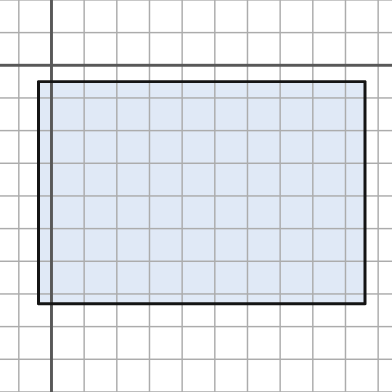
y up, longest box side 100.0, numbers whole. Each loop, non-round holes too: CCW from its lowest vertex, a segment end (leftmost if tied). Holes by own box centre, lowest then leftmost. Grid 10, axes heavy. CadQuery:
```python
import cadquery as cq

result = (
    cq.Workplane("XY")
    .moveTo(-4.0, -73.0)
    .lineTo(96.0, -73.0)
    .lineTo(96.0, -5.0)
    .lineTo(-4.0, -5.0)
    .close()
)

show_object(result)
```